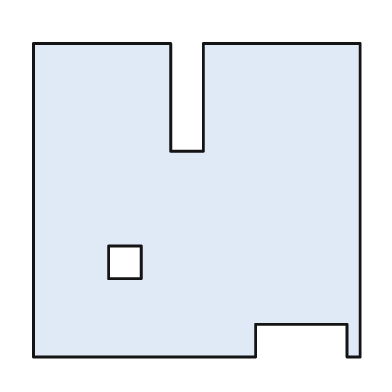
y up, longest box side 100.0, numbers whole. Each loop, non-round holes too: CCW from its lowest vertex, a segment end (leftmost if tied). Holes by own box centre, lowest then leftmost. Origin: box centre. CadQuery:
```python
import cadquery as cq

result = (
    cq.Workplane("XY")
    .moveTo(-50.0, -48.0)
    .lineTo(18.0, -48.0)
    .lineTo(18.0, -38.0)
    .lineTo(46.0, -38.0)
    .lineTo(46.0, -48.0)
    .lineTo(50.0, -48.0)
    .lineTo(50.0, 48.0)
    .lineTo(2.0, 48.0)
    .lineTo(2.0, 15.0)
    .lineTo(-8.0, 15.0)
    .lineTo(-8.0, 48.0)
    .lineTo(-50.0, 48.0)
    .close()
    .moveTo(-27.0, -24.0)
    .lineTo(-17.0, -24.0)
    .lineTo(-17.0, -14.0)
    .lineTo(-27.0, -14.0)
    .close()
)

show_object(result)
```